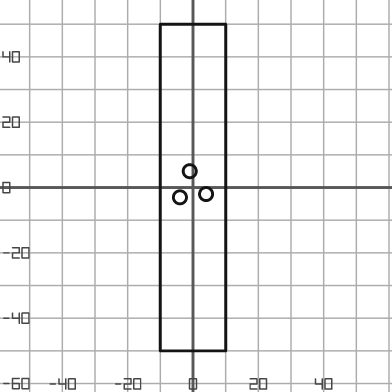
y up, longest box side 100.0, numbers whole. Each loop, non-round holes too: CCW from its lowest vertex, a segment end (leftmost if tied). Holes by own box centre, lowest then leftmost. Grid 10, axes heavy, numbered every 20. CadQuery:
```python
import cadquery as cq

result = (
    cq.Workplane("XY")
    .moveTo(-10.0, -50.0)
    .lineTo(10.0, -50.0)
    .lineTo(10.0, 50.0)
    .lineTo(-10.0, 50.0)
    .close()
    .moveTo(-4.0, -3.0)
    .circle(2.0)
    .moveTo(4.0, -2.0)
    .circle(2.0)
    .moveTo(-1.0, 5.0)
    .circle(2.0)
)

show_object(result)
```